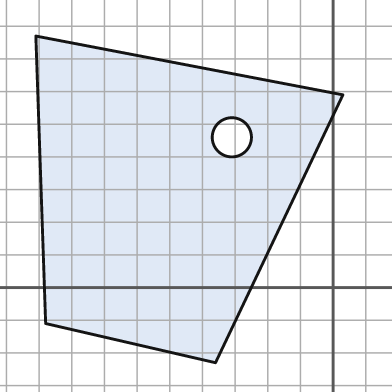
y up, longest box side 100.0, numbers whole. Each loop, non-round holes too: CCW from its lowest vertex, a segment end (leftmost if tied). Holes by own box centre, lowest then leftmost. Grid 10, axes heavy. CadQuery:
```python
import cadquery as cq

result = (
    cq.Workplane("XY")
    .moveTo(-36.0, -23.0)
    .lineTo(3.0, 59.0)
    .lineTo(-91.0, 77.0)
    .lineTo(-88.0, -11.0)
    .close()
    .moveTo(-31.0, 46.0)
    .circle(6.0)
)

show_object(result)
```